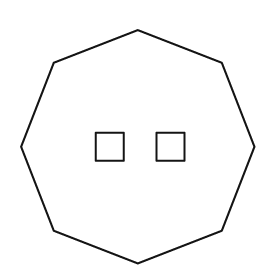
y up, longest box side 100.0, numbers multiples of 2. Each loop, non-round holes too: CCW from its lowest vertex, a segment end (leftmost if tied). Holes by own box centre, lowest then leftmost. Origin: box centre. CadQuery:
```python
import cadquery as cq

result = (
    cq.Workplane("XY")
    .moveTo(0.0, -50.0)
    .lineTo(36.0, -36.0)
    .lineTo(50.0, 0.0)
    .lineTo(36.0, 36.0)
    .lineTo(0.0, 50.0)
    .lineTo(-36.0, 36.0)
    .lineTo(-50.0, 0.0)
    .lineTo(-36.0, -36.0)
    .close()
    .moveTo(-18.0, -6.0)
    .lineTo(-6.0, -6.0)
    .lineTo(-6.0, 6.0)
    .lineTo(-18.0, 6.0)
    .close()
    .moveTo(8.0, -6.0)
    .lineTo(20.0, -6.0)
    .lineTo(20.0, 6.0)
    .lineTo(8.0, 6.0)
    .close()
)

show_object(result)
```